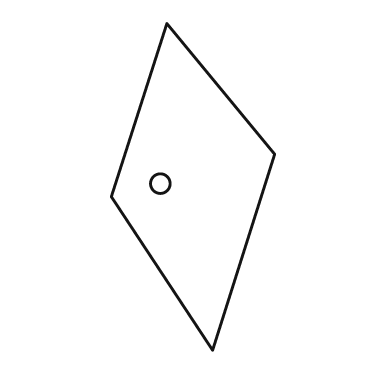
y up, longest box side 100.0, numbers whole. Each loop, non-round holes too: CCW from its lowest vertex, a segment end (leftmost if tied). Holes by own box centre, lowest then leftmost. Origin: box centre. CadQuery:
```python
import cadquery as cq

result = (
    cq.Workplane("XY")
    .moveTo(6.0, -50.0)
    .lineTo(25.0, 10.0)
    .lineTo(-8.0, 50.0)
    .lineTo(-25.0, -3.0)
    .close()
    .moveTo(-10.0, 1.0)
    .circle(3.0)
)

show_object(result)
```